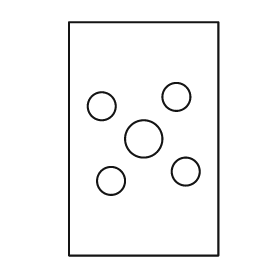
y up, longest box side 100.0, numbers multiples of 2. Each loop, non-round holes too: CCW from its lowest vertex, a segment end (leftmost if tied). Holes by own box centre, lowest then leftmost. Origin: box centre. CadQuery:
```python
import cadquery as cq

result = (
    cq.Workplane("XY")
    .moveTo(-32.0, -50.0)
    .lineTo(32.0, -50.0)
    .lineTo(32.0, 50.0)
    .lineTo(-32.0, 50.0)
    .close()
    .moveTo(-14.0, -18.0)
    .circle(6.0)
    .moveTo(18.0, -14.0)
    .circle(6.0)
    .moveTo(0.0, 0.0)
    .circle(8.0)
    .moveTo(-18.0, 14.0)
    .circle(6.0)
    .moveTo(14.0, 18.0)
    .circle(6.0)
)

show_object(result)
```